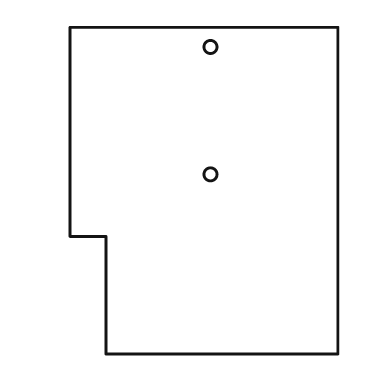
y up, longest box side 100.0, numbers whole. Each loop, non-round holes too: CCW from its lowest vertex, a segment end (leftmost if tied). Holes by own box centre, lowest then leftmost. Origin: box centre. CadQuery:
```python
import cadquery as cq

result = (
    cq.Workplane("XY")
    .moveTo(-30.0, -50.0)
    .lineTo(41.0, -50.0)
    .lineTo(41.0, 50.0)
    .lineTo(-41.0, 50.0)
    .lineTo(-41.0, -14.0)
    .lineTo(-30.0, -14.0)
    .close()
    .moveTo(2.0, 5.0)
    .circle(2.0)
    .moveTo(2.0, 44.0)
    .circle(2.0)
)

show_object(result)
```